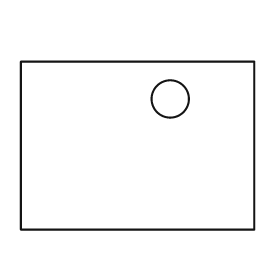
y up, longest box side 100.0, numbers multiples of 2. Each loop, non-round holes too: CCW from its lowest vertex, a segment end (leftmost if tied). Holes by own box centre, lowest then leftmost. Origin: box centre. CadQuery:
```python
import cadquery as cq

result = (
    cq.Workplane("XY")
    .moveTo(-50.0, -36.0)
    .lineTo(50.0, -36.0)
    .lineTo(50.0, 36.0)
    .lineTo(-50.0, 36.0)
    .close()
    .moveTo(14.0, 20.0)
    .circle(8.0)
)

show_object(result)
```